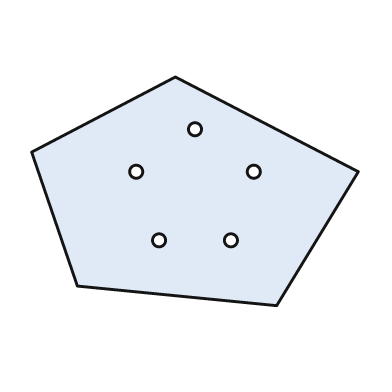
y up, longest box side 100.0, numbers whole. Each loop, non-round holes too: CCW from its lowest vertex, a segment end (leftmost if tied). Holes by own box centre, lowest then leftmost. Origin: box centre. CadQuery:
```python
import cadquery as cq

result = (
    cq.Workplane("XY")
    .moveTo(25.0, -35.0)
    .lineTo(50.0, 6.0)
    .lineTo(-6.0, 35.0)
    .lineTo(-50.0, 12.0)
    .lineTo(-36.0, -29.0)
    .close()
    .moveTo(-11.0, -15.0)
    .circle(2.0)
    .moveTo(11.0, -15.0)
    .circle(2.0)
    .moveTo(-18.0, 6.0)
    .circle(2.0)
    .moveTo(18.0, 6.0)
    .circle(2.0)
    .moveTo(0.0, 19.0)
    .circle(2.0)
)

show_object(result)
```